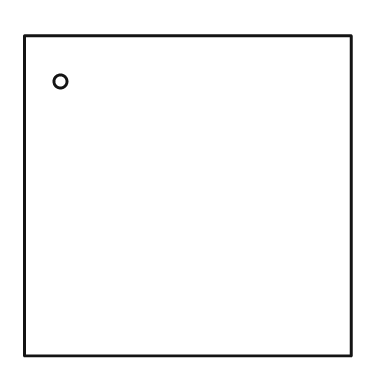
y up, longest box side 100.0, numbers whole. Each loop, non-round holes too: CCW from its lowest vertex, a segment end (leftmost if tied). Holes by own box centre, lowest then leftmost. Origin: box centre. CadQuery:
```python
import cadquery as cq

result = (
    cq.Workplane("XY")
    .moveTo(-50.0, -49.0)
    .lineTo(50.0, -49.0)
    .lineTo(50.0, 49.0)
    .lineTo(-50.0, 49.0)
    .close()
    .moveTo(-39.0, 35.0)
    .circle(2.0)
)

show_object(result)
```